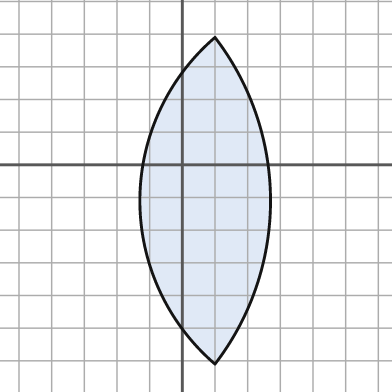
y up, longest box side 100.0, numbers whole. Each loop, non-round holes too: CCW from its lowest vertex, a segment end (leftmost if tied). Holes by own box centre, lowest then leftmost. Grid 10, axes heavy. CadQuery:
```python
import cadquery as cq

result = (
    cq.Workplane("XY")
    .moveTo(10.0, -61.0)
    .threePointArc((27.0, -11.0), (10.0, 39.0))
    .threePointArc((-13.0, -11.0), (10.0, -61.0))
    .close()
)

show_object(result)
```